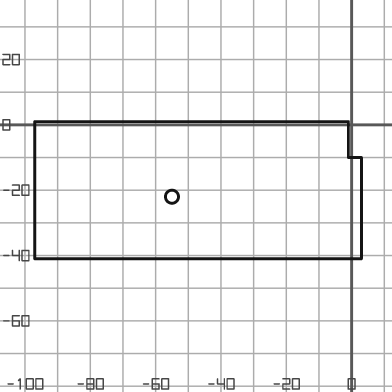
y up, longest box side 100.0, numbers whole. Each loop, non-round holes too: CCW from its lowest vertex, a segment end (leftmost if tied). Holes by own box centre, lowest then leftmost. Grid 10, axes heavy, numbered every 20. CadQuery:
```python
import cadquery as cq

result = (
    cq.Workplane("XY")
    .moveTo(-97.0, -41.0)
    .lineTo(3.0, -41.0)
    .lineTo(3.0, -10.0)
    .lineTo(-1.0, -10.0)
    .lineTo(-1.0, 1.0)
    .lineTo(-97.0, 1.0)
    .close()
    .moveTo(-55.0, -22.0)
    .circle(2.0)
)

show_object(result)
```